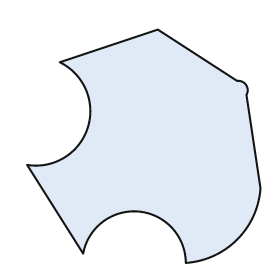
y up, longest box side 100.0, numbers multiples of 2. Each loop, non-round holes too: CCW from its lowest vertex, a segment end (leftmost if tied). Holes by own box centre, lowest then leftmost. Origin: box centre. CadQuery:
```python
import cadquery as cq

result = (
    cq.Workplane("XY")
    .moveTo(18.0, -50.0)
    .threePointArc((40.0, -40.0), (50.0, -18.0))
    .lineTo(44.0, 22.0)
    .threePointArc((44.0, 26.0), (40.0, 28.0))
    .lineTo(6.0, 50.0)
    .lineTo(-36.0, 36.0)
    .threePointArc((-24.0, 8.0), (-50.0, -8.0))
    .lineTo(-26.0, -46.0)
    .threePointArc((-2.0, -28.0), (18.0, -50.0))
    .close()
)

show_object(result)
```